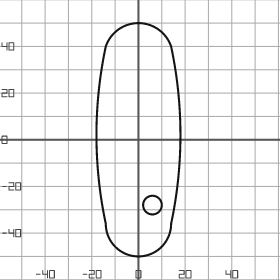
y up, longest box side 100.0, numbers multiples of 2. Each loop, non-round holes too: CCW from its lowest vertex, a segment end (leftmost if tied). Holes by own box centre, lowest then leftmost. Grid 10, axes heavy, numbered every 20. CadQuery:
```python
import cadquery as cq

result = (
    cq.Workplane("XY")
    .moveTo(-14.0, -36.0)
    .threePointArc((0.0, -50.0), (14.0, -36.0))
    .threePointArc((18.0, 2.0), (14.0, 40.0))
    .threePointArc((0.0, 50.0), (-14.0, 40.0))
    .threePointArc((-18.0, 2.0), (-14.0, -36.0))
    .close()
    .moveTo(6.0, -28.0)
    .circle(4.0)
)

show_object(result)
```